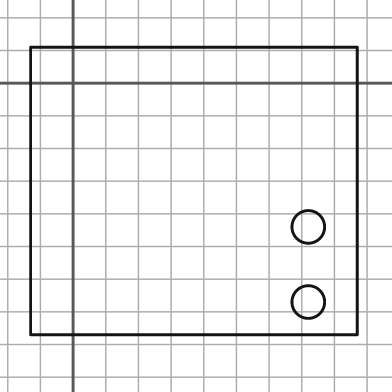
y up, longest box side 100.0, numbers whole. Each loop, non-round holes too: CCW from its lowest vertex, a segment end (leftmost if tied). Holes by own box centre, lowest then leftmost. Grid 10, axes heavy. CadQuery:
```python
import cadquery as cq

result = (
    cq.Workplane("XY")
    .moveTo(-13.0, -77.0)
    .lineTo(87.0, -77.0)
    .lineTo(87.0, 11.0)
    .lineTo(-13.0, 11.0)
    .close()
    .moveTo(72.0, -67.0)
    .circle(5.0)
    .moveTo(72.0, -44.0)
    .circle(5.0)
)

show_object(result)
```